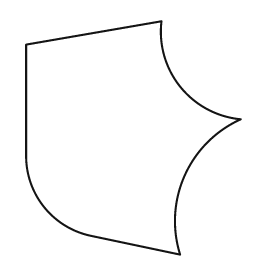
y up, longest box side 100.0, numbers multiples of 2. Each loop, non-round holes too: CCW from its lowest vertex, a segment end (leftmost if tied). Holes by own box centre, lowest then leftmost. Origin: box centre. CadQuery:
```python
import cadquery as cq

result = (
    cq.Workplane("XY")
    .moveTo(20.0, -50.0)
    .threePointArc((22.0, -16.0), (46.0, 8.0))
    .threePointArc((20.0, 22.0), (12.0, 50.0))
    .lineTo(-46.0, 40.0)
    .lineTo(-46.0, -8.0)
    .threePointArc((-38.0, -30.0), (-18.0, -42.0))
    .close()
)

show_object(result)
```